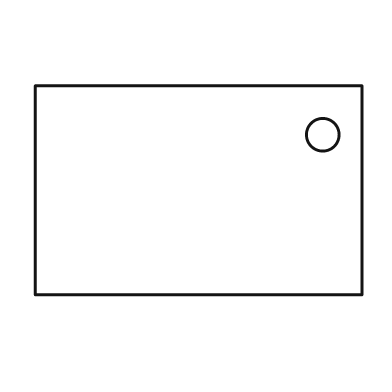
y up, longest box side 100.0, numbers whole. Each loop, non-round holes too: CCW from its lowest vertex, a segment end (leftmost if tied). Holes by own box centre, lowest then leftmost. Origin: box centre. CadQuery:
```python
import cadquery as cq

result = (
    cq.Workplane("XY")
    .moveTo(-50.0, -32.0)
    .lineTo(50.0, -32.0)
    .lineTo(50.0, 32.0)
    .lineTo(-50.0, 32.0)
    .close()
    .moveTo(38.0, 17.0)
    .circle(5.0)
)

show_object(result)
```